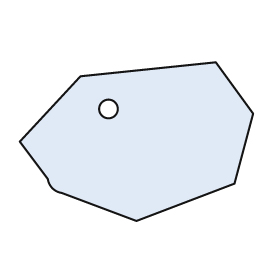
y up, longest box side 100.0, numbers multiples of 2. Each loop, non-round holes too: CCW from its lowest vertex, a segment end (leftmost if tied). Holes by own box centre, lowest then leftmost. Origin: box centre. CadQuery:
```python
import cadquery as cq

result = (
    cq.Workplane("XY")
    .moveTo(0.0, -34.0)
    .lineTo(42.0, -18.0)
    .lineTo(50.0, 12.0)
    .lineTo(34.0, 34.0)
    .lineTo(-24.0, 28.0)
    .lineTo(-50.0, 0.0)
    .lineTo(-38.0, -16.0)
    .threePointArc((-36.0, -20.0), (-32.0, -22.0))
    .close()
    .moveTo(-12.0, 14.0)
    .circle(4.0)
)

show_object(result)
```